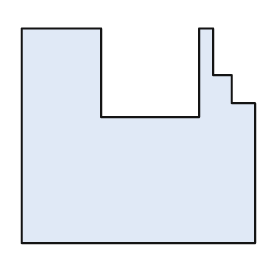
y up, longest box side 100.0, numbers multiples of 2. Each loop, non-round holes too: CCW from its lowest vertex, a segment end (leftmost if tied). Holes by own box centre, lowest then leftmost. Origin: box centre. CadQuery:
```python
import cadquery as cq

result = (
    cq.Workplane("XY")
    .moveTo(-50.0, -46.0)
    .lineTo(50.0, -46.0)
    .lineTo(50.0, 14.0)
    .lineTo(40.0, 14.0)
    .lineTo(40.0, 26.0)
    .lineTo(32.0, 26.0)
    .lineTo(32.0, 46.0)
    .lineTo(26.0, 46.0)
    .lineTo(26.0, 8.0)
    .lineTo(-16.0, 8.0)
    .lineTo(-16.0, 46.0)
    .lineTo(-50.0, 46.0)
    .close()
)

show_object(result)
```